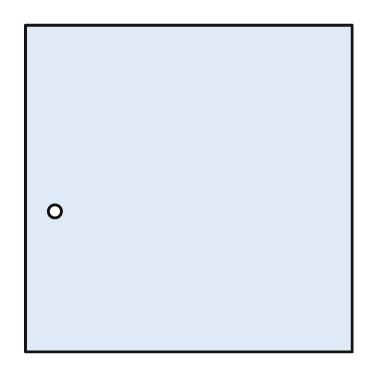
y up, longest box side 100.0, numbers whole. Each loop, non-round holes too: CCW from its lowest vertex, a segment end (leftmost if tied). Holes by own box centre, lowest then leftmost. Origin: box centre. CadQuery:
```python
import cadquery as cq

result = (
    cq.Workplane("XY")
    .moveTo(-50.0, -50.0)
    .lineTo(50.0, -50.0)
    .lineTo(50.0, 50.0)
    .lineTo(-50.0, 50.0)
    .close()
    .moveTo(-41.0, -7.0)
    .circle(2.0)
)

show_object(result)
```